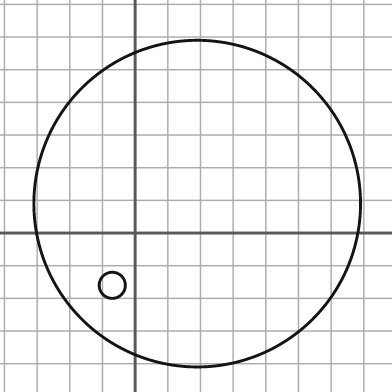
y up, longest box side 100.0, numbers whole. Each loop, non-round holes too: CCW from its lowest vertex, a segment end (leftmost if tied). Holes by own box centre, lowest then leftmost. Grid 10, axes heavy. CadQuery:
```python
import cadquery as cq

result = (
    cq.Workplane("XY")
    .moveTo(19.0, 9.0)
    .circle(50.0)
    .moveTo(-7.0, -16.0)
    .circle(4.0)
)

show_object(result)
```